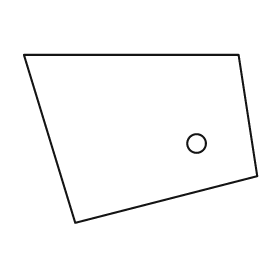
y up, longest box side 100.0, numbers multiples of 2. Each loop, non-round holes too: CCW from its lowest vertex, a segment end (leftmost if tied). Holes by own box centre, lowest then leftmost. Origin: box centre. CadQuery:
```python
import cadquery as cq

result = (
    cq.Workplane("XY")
    .moveTo(-28.0, -36.0)
    .lineTo(50.0, -16.0)
    .lineTo(42.0, 36.0)
    .lineTo(-50.0, 36.0)
    .close()
    .moveTo(24.0, -2.0)
    .circle(4.0)
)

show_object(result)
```